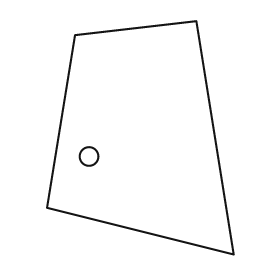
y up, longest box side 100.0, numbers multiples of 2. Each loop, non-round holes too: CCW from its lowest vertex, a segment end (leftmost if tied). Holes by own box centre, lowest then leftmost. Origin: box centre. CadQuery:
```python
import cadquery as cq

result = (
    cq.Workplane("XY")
    .moveTo(40.0, -50.0)
    .lineTo(24.0, 50.0)
    .lineTo(-28.0, 44.0)
    .lineTo(-40.0, -30.0)
    .close()
    .moveTo(-22.0, -8.0)
    .circle(4.0)
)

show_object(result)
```